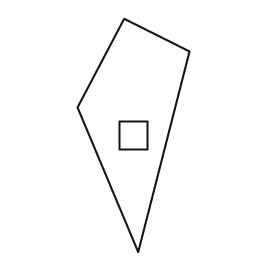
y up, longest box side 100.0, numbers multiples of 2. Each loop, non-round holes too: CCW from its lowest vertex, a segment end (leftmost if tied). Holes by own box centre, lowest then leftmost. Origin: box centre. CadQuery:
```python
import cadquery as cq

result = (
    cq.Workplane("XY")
    .moveTo(2.0, -50.0)
    .lineTo(24.0, 36.0)
    .lineTo(-4.0, 50.0)
    .lineTo(-24.0, 12.0)
    .close()
    .moveTo(-6.0, -6.0)
    .lineTo(6.0, -6.0)
    .lineTo(6.0, 6.0)
    .lineTo(-6.0, 6.0)
    .close()
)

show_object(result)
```